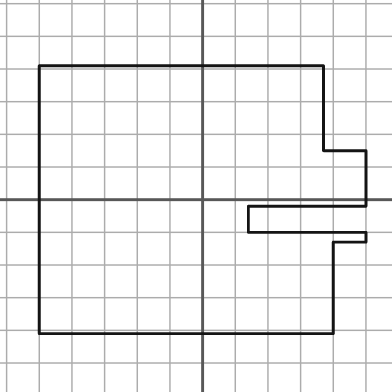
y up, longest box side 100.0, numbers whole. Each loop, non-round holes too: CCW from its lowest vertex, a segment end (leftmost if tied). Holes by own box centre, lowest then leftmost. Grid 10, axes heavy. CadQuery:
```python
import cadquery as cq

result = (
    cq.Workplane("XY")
    .moveTo(-50.0, -41.0)
    .lineTo(40.0, -41.0)
    .lineTo(40.0, -13.0)
    .lineTo(50.0, -13.0)
    .lineTo(50.0, -10.0)
    .lineTo(14.0, -10.0)
    .lineTo(14.0, -2.0)
    .lineTo(50.0, -2.0)
    .lineTo(50.0, 15.0)
    .lineTo(37.0, 15.0)
    .lineTo(37.0, 41.0)
    .lineTo(-50.0, 41.0)
    .close()
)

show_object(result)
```